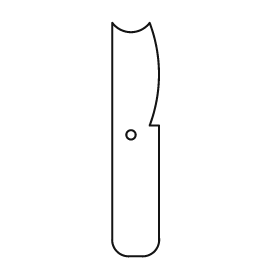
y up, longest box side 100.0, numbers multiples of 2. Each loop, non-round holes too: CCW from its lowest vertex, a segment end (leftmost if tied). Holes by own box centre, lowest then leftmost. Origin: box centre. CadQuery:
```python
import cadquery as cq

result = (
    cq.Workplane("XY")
    .moveTo(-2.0, -50.0)
    .lineTo(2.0, -50.0)
    .threePointArc((8.0, -48.0), (10.0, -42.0))
    .lineTo(10.0, 6.0)
    .lineTo(6.0, 6.0)
    .threePointArc((10.0, 28.0), (6.0, 50.0))
    .threePointArc((-2.0, 46.0), (-10.0, 50.0))
    .lineTo(-10.0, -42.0)
    .threePointArc((-8.0, -48.0), (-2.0, -50.0))
    .close()
    .moveTo(-2.0, 2.0)
    .circle(2.0)
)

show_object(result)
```